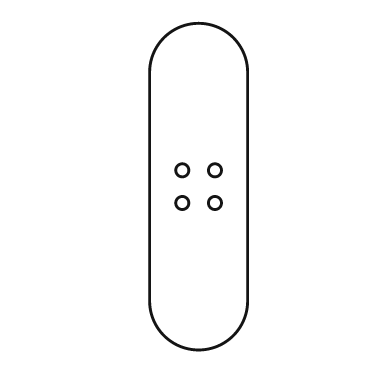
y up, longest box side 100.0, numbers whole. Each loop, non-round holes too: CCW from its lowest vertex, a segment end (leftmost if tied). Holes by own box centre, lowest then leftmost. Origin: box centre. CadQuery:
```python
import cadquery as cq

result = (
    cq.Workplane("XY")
    .moveTo(-15.0, -35.0)
    .threePointArc((0.0, -50.0), (15.0, -35.0))
    .lineTo(15.0, 35.0)
    .threePointArc((0.0, 50.0), (-15.0, 35.0))
    .close()
    .moveTo(-5.0, -5.0)
    .circle(2.0)
    .moveTo(5.0, -5.0)
    .circle(2.0)
    .moveTo(-5.0, 5.0)
    .circle(2.0)
    .moveTo(5.0, 5.0)
    .circle(2.0)
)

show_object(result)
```